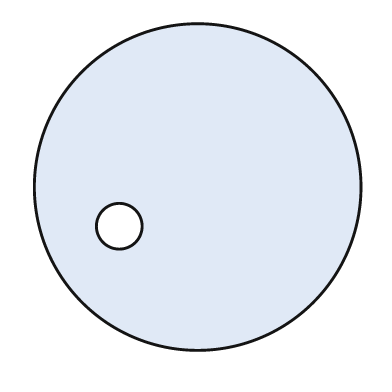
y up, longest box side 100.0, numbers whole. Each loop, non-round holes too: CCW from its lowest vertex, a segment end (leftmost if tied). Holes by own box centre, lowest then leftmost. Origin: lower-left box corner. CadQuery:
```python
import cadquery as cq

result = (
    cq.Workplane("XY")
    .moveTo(50.0, 50.0)
    .circle(50.0)
    .moveTo(26.0, 38.0)
    .circle(7.0)
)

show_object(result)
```